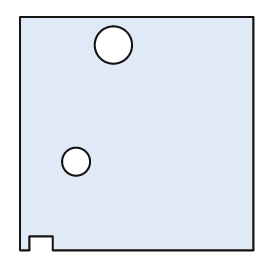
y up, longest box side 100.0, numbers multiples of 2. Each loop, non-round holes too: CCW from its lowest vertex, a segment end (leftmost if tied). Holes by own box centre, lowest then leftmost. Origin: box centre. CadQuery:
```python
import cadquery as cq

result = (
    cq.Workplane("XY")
    .moveTo(-50.0, -50.0)
    .lineTo(-46.0, -50.0)
    .lineTo(-46.0, -44.0)
    .lineTo(-36.0, -44.0)
    .lineTo(-36.0, -50.0)
    .lineTo(50.0, -50.0)
    .lineTo(50.0, 50.0)
    .lineTo(-50.0, 50.0)
    .close()
    .moveTo(-26.0, -12.0)
    .circle(6.0)
    .moveTo(-10.0, 38.0)
    .circle(8.0)
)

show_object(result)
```